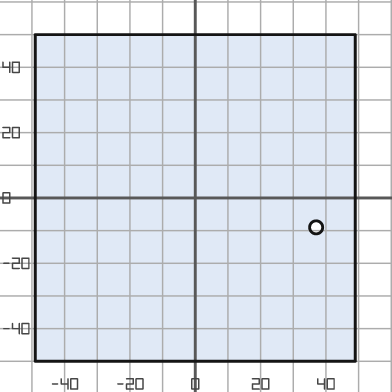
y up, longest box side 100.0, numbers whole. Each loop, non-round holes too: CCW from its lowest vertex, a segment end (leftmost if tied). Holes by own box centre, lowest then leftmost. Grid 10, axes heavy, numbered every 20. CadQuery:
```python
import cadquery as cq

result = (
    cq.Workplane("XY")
    .moveTo(-49.0, -50.0)
    .lineTo(49.0, -50.0)
    .lineTo(49.0, 50.0)
    .lineTo(-49.0, 50.0)
    .close()
    .moveTo(37.0, -9.0)
    .circle(2.0)
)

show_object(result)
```